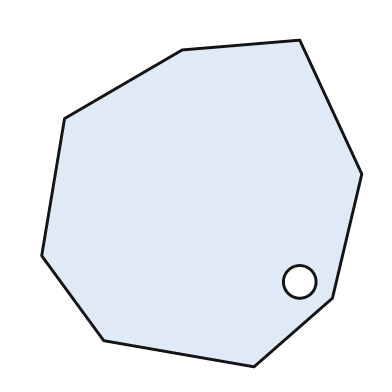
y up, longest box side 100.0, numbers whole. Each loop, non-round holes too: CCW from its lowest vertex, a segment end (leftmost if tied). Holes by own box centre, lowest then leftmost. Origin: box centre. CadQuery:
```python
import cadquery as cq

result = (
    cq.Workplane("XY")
    .moveTo(16.0, -50.0)
    .lineTo(40.0, -29.0)
    .lineTo(49.0, 9.0)
    .lineTo(30.0, 50.0)
    .lineTo(-6.0, 47.0)
    .lineTo(-42.0, 26.0)
    .lineTo(-49.0, -16.0)
    .lineTo(-30.0, -42.0)
    .close()
    .moveTo(30.0, -24.0)
    .circle(5.0)
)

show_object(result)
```